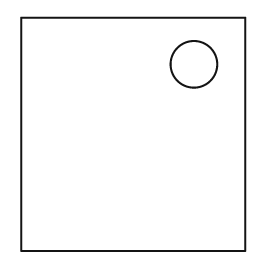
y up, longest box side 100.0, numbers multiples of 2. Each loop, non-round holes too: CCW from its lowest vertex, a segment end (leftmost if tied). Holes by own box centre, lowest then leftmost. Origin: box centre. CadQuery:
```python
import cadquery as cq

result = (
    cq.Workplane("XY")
    .moveTo(-48.0, -50.0)
    .lineTo(48.0, -50.0)
    .lineTo(48.0, 50.0)
    .lineTo(-48.0, 50.0)
    .close()
    .moveTo(26.0, 30.0)
    .circle(10.0)
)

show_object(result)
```